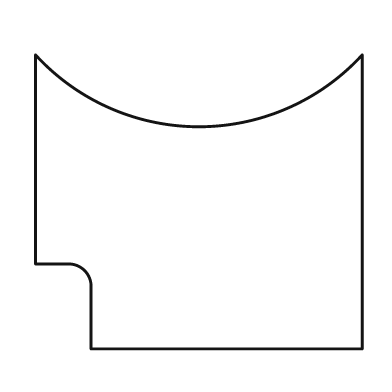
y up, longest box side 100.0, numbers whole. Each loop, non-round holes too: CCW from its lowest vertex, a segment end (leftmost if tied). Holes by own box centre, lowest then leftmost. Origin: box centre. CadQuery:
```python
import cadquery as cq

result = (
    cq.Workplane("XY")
    .moveTo(-33.0, -45.0)
    .lineTo(50.0, -45.0)
    .lineTo(50.0, 45.0)
    .threePointArc((0.0, 23.0), (-50.0, 45.0))
    .lineTo(-50.0, -19.0)
    .lineTo(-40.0, -19.0)
    .threePointArc((-35.0, -21.0), (-33.0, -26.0))
    .close()
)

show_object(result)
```